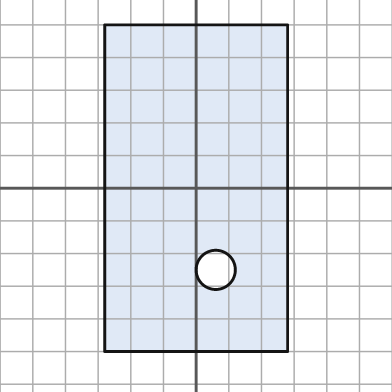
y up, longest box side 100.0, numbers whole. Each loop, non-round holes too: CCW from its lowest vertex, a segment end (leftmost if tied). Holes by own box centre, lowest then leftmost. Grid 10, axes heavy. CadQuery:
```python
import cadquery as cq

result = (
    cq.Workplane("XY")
    .moveTo(-28.0, -50.0)
    .lineTo(28.0, -50.0)
    .lineTo(28.0, 50.0)
    .lineTo(-28.0, 50.0)
    .close()
    .moveTo(6.0, -25.0)
    .circle(6.0)
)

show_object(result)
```